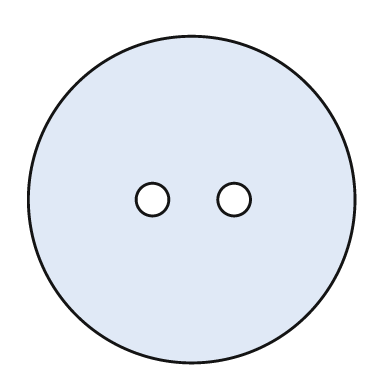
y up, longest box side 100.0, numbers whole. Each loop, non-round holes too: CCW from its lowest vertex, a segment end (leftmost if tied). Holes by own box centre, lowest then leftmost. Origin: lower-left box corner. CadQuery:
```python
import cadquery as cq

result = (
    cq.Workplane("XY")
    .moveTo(50.0, 50.0)
    .circle(50.0)
    .moveTo(38.0, 50.0)
    .circle(5.0)
    .moveTo(63.0, 50.0)
    .circle(5.0)
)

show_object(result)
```